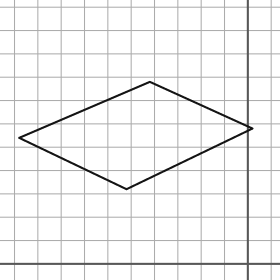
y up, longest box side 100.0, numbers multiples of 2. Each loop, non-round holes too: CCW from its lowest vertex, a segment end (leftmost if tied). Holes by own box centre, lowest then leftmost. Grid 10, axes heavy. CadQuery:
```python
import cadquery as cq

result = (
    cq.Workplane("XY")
    .moveTo(-52.0, 32.0)
    .lineTo(2.0, 58.0)
    .lineTo(-42.0, 78.0)
    .lineTo(-98.0, 54.0)
    .close()
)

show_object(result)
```